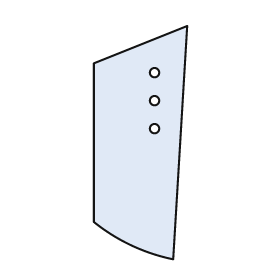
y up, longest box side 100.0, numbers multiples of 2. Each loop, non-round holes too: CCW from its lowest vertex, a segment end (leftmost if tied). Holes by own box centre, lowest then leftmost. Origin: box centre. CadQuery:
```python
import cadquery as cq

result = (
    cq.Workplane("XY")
    .moveTo(14.0, -50.0)
    .lineTo(20.0, 50.0)
    .lineTo(-20.0, 34.0)
    .lineTo(-20.0, -34.0)
    .threePointArc((-4.0, -44.0), (14.0, -50.0))
    .close()
    .moveTo(6.0, 6.0)
    .circle(2.0)
    .moveTo(6.0, 18.0)
    .circle(2.0)
    .moveTo(6.0, 30.0)
    .circle(2.0)
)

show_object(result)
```